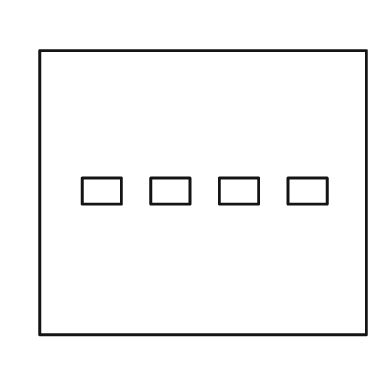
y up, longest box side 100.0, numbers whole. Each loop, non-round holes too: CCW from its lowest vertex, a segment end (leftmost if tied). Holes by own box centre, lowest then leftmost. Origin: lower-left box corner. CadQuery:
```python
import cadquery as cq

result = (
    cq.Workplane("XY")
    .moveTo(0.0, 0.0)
    .lineTo(100.0, 0.0)
    .lineTo(100.0, 87.0)
    .lineTo(0.0, 87.0)
    .close()
    .moveTo(13.0, 40.0)
    .lineTo(25.0, 40.0)
    .lineTo(25.0, 48.0)
    .lineTo(13.0, 48.0)
    .close()
    .moveTo(34.0, 40.0)
    .lineTo(46.0, 40.0)
    .lineTo(46.0, 48.0)
    .lineTo(34.0, 48.0)
    .close()
    .moveTo(55.0, 40.0)
    .lineTo(67.0, 40.0)
    .lineTo(67.0, 48.0)
    .lineTo(55.0, 48.0)
    .close()
    .moveTo(76.0, 40.0)
    .lineTo(88.0, 40.0)
    .lineTo(88.0, 48.0)
    .lineTo(76.0, 48.0)
    .close()
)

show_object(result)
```